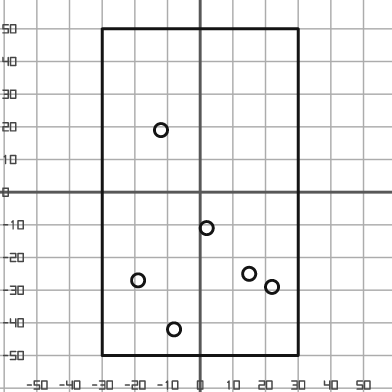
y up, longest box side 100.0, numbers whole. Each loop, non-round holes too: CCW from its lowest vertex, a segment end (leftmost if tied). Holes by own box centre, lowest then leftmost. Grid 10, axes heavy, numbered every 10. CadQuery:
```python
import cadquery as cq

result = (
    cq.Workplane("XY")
    .moveTo(-30.0, -50.0)
    .lineTo(30.0, -50.0)
    .lineTo(30.0, 50.0)
    .lineTo(-30.0, 50.0)
    .close()
    .moveTo(-8.0, -42.0)
    .circle(2.0)
    .moveTo(22.0, -29.0)
    .circle(2.0)
    .moveTo(-19.0, -27.0)
    .circle(2.0)
    .moveTo(15.0, -25.0)
    .circle(2.0)
    .moveTo(2.0, -11.0)
    .circle(2.0)
    .moveTo(-12.0, 19.0)
    .circle(2.0)
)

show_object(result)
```